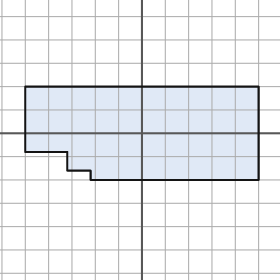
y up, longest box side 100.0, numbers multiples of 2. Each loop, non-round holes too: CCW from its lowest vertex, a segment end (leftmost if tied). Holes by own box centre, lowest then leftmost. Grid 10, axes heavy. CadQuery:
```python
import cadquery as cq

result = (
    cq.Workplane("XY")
    .moveTo(-22.0, -20.0)
    .lineTo(50.0, -20.0)
    .lineTo(50.0, 20.0)
    .lineTo(-50.0, 20.0)
    .lineTo(-50.0, -8.0)
    .lineTo(-32.0, -8.0)
    .lineTo(-32.0, -16.0)
    .lineTo(-22.0, -16.0)
    .close()
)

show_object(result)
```